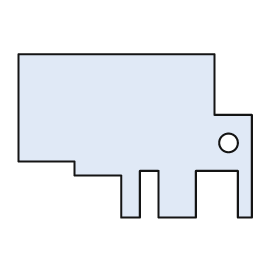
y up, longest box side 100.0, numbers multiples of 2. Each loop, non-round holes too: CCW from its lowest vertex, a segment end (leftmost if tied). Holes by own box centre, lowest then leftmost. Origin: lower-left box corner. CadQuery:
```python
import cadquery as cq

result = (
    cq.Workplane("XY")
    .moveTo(44.0, 0.0)
    .lineTo(52.0, 0.0)
    .lineTo(52.0, 20.0)
    .lineTo(60.0, 20.0)
    .lineTo(60.0, 0.0)
    .lineTo(76.0, 0.0)
    .lineTo(76.0, 20.0)
    .lineTo(94.0, 20.0)
    .lineTo(94.0, 0.0)
    .lineTo(100.0, 0.0)
    .lineTo(100.0, 44.0)
    .lineTo(84.0, 44.0)
    .lineTo(84.0, 70.0)
    .lineTo(0.0, 70.0)
    .lineTo(0.0, 24.0)
    .lineTo(24.0, 24.0)
    .lineTo(24.0, 18.0)
    .lineTo(44.0, 18.0)
    .close()
    .moveTo(90.0, 32.0)
    .circle(4.0)
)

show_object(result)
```